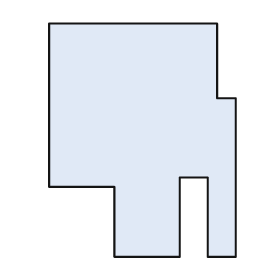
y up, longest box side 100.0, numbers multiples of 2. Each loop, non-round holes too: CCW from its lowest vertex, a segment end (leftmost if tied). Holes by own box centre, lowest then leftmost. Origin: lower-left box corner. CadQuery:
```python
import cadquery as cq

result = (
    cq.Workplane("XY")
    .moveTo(28.0, 0.0)
    .lineTo(56.0, 0.0)
    .lineTo(56.0, 34.0)
    .lineTo(68.0, 34.0)
    .lineTo(68.0, 0.0)
    .lineTo(80.0, 0.0)
    .lineTo(80.0, 68.0)
    .lineTo(72.0, 68.0)
    .lineTo(72.0, 100.0)
    .lineTo(0.0, 100.0)
    .lineTo(0.0, 30.0)
    .lineTo(28.0, 30.0)
    .close()
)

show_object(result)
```